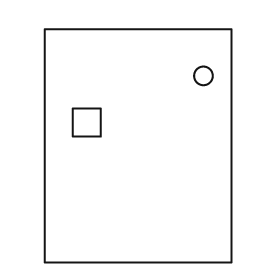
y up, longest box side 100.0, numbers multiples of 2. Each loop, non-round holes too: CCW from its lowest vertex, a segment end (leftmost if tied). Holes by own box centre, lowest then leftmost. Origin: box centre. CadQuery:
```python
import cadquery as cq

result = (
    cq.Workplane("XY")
    .moveTo(-40.0, -50.0)
    .lineTo(40.0, -50.0)
    .lineTo(40.0, 50.0)
    .lineTo(-40.0, 50.0)
    .close()
    .moveTo(-28.0, 4.0)
    .lineTo(-16.0, 4.0)
    .lineTo(-16.0, 16.0)
    .lineTo(-28.0, 16.0)
    .close()
    .moveTo(28.0, 30.0)
    .circle(4.0)
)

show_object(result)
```